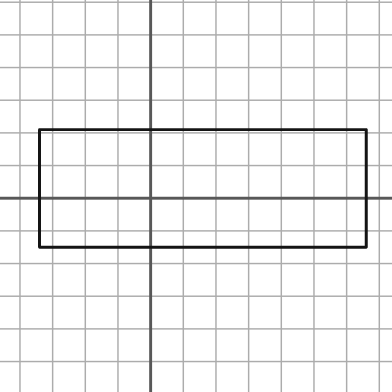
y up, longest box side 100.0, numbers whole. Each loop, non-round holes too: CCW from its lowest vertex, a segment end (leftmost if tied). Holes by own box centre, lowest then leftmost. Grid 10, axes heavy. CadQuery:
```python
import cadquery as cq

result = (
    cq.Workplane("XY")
    .moveTo(-34.0, -15.0)
    .lineTo(66.0, -15.0)
    .lineTo(66.0, 21.0)
    .lineTo(-34.0, 21.0)
    .close()
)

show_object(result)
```